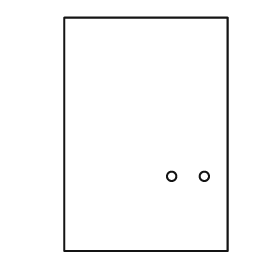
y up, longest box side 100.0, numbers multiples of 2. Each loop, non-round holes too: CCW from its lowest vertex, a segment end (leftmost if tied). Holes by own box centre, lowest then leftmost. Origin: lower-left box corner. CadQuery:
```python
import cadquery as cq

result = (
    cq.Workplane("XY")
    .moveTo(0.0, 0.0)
    .lineTo(70.0, 0.0)
    .lineTo(70.0, 100.0)
    .lineTo(0.0, 100.0)
    .close()
    .moveTo(46.0, 32.0)
    .circle(2.0)
    .moveTo(60.0, 32.0)
    .circle(2.0)
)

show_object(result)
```